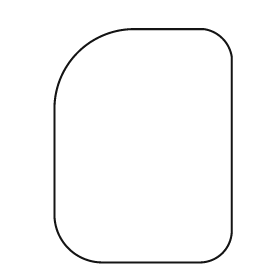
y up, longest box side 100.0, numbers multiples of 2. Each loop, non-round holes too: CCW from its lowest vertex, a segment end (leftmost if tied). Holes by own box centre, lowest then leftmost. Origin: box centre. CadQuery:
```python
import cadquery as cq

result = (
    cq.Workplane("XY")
    .moveTo(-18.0, -50.0)
    .lineTo(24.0, -50.0)
    .threePointArc((34.0, -46.0), (38.0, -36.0))
    .lineTo(38.0, 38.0)
    .threePointArc((34.0, 46.0), (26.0, 50.0))
    .lineTo(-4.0, 50.0)
    .threePointArc((-28.0, 40.0), (-38.0, 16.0))
    .lineTo(-38.0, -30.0)
    .threePointArc((-32.0, -44.0), (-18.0, -50.0))
    .close()
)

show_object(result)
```